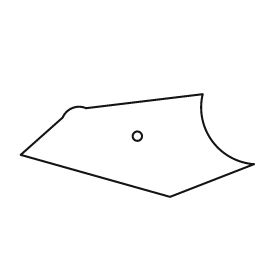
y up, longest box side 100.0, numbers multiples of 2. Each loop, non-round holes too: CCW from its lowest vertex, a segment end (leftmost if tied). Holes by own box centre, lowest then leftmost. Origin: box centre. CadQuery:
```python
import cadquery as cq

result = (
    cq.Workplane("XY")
    .moveTo(14.0, -22.0)
    .lineTo(50.0, -8.0)
    .threePointArc((32.0, 2.0), (28.0, 22.0))
    .lineTo(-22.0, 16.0)
    .threePointArc((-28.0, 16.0), (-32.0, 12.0))
    .lineTo(-50.0, -4.0)
    .close()
    .moveTo(0.0, 4.0)
    .circle(2.0)
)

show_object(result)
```